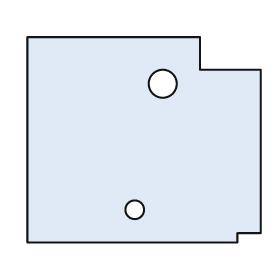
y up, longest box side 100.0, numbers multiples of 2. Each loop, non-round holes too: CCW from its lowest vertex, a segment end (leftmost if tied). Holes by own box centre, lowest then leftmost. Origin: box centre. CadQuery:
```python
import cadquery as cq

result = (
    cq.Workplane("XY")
    .moveTo(-50.0, -44.0)
    .lineTo(40.0, -44.0)
    .lineTo(40.0, -40.0)
    .lineTo(50.0, -40.0)
    .lineTo(50.0, 30.0)
    .lineTo(24.0, 30.0)
    .lineTo(24.0, 44.0)
    .lineTo(-50.0, 44.0)
    .close()
    .moveTo(-4.0, -30.0)
    .circle(4.0)
    .moveTo(8.0, 24.0)
    .circle(6.0)
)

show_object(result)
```